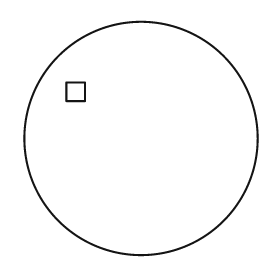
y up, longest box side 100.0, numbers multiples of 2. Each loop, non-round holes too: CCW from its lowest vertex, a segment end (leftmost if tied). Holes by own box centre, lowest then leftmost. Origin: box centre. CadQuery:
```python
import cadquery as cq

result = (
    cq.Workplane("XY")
    .moveTo(0.0, 0.0)
    .circle(50.0)
    .moveTo(-32.0, 16.0)
    .lineTo(-24.0, 16.0)
    .lineTo(-24.0, 24.0)
    .lineTo(-32.0, 24.0)
    .close()
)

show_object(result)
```